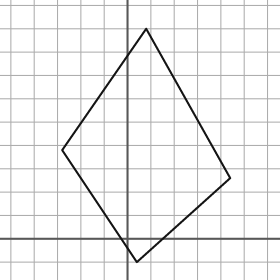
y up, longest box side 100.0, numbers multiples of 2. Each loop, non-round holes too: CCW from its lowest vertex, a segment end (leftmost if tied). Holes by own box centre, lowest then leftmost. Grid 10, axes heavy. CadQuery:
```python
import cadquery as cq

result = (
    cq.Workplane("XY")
    .moveTo(4.0, -10.0)
    .lineTo(44.0, 26.0)
    .lineTo(8.0, 90.0)
    .lineTo(-28.0, 38.0)
    .close()
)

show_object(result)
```